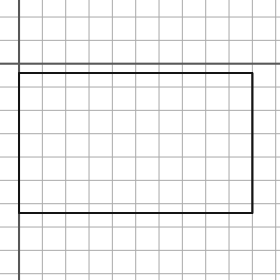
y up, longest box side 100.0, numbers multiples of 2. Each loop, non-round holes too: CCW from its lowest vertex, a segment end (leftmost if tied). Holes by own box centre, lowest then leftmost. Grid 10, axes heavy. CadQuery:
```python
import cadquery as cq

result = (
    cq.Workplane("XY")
    .moveTo(0.0, -64.0)
    .lineTo(100.0, -64.0)
    .lineTo(100.0, -4.0)
    .lineTo(0.0, -4.0)
    .close()
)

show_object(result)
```